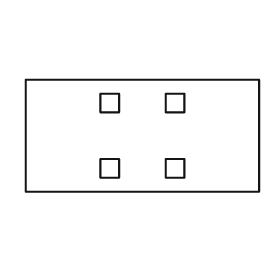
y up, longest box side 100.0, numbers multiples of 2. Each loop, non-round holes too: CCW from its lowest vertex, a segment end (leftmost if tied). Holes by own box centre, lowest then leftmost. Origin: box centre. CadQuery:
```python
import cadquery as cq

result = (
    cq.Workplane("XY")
    .moveTo(-50.0, -24.0)
    .lineTo(50.0, -24.0)
    .lineTo(50.0, 24.0)
    .lineTo(-50.0, 24.0)
    .close()
    .moveTo(-18.0, -18.0)
    .lineTo(-10.0, -18.0)
    .lineTo(-10.0, -10.0)
    .lineTo(-18.0, -10.0)
    .close()
    .moveTo(10.0, -18.0)
    .lineTo(18.0, -18.0)
    .lineTo(18.0, -10.0)
    .lineTo(10.0, -10.0)
    .close()
    .moveTo(-18.0, 10.0)
    .lineTo(-10.0, 10.0)
    .lineTo(-10.0, 18.0)
    .lineTo(-18.0, 18.0)
    .close()
    .moveTo(10.0, 10.0)
    .lineTo(18.0, 10.0)
    .lineTo(18.0, 18.0)
    .lineTo(10.0, 18.0)
    .close()
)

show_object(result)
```